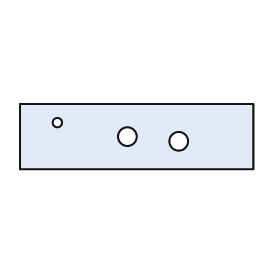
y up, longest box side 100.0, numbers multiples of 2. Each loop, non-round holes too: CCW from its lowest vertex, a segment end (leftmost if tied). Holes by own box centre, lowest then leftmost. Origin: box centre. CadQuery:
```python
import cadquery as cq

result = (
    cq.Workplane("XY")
    .moveTo(-50.0, -14.0)
    .lineTo(50.0, -14.0)
    .lineTo(50.0, 14.0)
    .lineTo(-50.0, 14.0)
    .close()
    .moveTo(18.0, -2.0)
    .circle(4.0)
    .moveTo(-4.0, 0.0)
    .circle(4.0)
    .moveTo(-34.0, 6.0)
    .circle(2.0)
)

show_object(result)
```